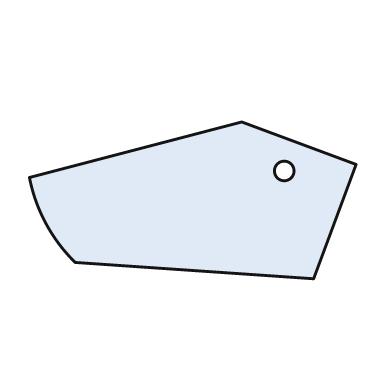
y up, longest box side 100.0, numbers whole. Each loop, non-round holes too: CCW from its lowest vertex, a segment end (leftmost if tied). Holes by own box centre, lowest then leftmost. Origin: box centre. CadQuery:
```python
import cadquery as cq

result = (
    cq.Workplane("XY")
    .moveTo(37.0, -24.0)
    .lineTo(50.0, 11.0)
    .lineTo(15.0, 24.0)
    .lineTo(-50.0, 7.0)
    .threePointArc((-45.0, -7.0), (-36.0, -19.0))
    .close()
    .moveTo(28.0, 9.0)
    .circle(3.0)
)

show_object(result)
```